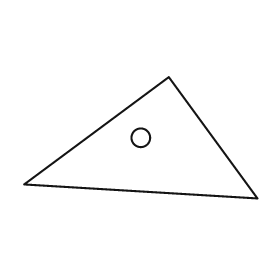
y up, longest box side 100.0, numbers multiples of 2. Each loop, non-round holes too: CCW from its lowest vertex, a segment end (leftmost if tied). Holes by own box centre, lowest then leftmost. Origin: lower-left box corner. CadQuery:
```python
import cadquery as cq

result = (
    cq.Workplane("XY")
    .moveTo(100.0, 0.0)
    .lineTo(62.0, 52.0)
    .lineTo(0.0, 6.0)
    .close()
    .moveTo(50.0, 26.0)
    .circle(4.0)
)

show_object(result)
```